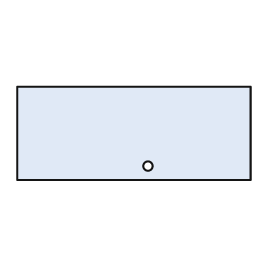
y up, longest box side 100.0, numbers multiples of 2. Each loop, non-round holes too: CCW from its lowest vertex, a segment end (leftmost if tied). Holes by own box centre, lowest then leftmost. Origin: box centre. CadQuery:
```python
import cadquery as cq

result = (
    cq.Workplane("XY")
    .moveTo(-50.0, -20.0)
    .lineTo(50.0, -20.0)
    .lineTo(50.0, 20.0)
    .lineTo(-50.0, 20.0)
    .close()
    .moveTo(6.0, -14.0)
    .circle(2.0)
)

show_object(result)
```